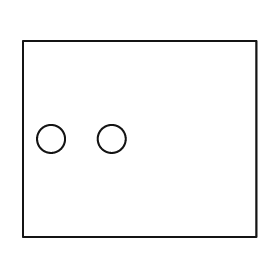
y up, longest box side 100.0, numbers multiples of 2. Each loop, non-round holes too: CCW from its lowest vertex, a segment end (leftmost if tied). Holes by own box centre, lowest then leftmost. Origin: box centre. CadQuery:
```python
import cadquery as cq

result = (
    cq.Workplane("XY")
    .moveTo(-50.0, -42.0)
    .lineTo(50.0, -42.0)
    .lineTo(50.0, 42.0)
    .lineTo(-50.0, 42.0)
    .close()
    .moveTo(-38.0, 0.0)
    .circle(6.0)
    .moveTo(-12.0, 0.0)
    .circle(6.0)
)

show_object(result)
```